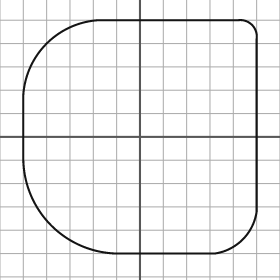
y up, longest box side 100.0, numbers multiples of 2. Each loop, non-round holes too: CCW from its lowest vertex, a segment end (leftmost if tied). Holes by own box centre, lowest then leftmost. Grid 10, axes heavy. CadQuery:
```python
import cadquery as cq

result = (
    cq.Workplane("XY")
    .moveTo(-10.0, -50.0)
    .lineTo(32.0, -50.0)
    .threePointArc((44.0, -44.0), (50.0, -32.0))
    .lineTo(50.0, 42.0)
    .threePointArc((48.0, 48.0), (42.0, 50.0))
    .lineTo(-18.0, 50.0)
    .threePointArc((-40.0, 40.0), (-50.0, 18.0))
    .lineTo(-50.0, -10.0)
    .threePointArc((-38.0, -38.0), (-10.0, -50.0))
    .close()
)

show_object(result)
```